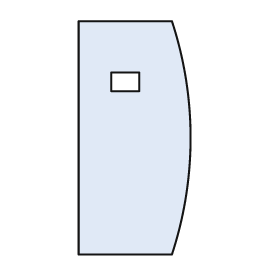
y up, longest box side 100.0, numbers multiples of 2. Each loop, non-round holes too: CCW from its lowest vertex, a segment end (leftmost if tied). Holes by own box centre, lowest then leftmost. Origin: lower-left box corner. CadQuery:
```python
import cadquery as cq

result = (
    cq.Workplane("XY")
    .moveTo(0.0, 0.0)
    .lineTo(40.0, 0.0)
    .threePointArc((48.0, 50.0), (40.0, 100.0))
    .lineTo(0.0, 100.0)
    .close()
    .moveTo(14.0, 70.0)
    .lineTo(26.0, 70.0)
    .lineTo(26.0, 78.0)
    .lineTo(14.0, 78.0)
    .close()
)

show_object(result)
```